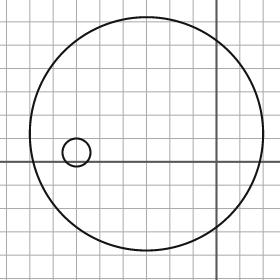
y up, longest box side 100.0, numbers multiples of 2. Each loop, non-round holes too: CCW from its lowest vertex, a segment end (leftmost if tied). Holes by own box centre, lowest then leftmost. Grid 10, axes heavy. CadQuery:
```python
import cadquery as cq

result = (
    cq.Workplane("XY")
    .moveTo(-30.0, 12.0)
    .circle(50.0)
    .moveTo(-60.0, 4.0)
    .circle(6.0)
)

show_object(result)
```